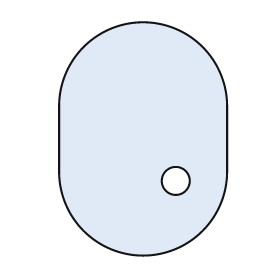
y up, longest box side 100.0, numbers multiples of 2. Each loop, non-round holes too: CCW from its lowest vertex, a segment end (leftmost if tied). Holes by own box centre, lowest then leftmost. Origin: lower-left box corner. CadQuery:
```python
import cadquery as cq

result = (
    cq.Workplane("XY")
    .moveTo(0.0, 36.0)
    .threePointArc((36.0, 0.0), (72.0, 36.0))
    .lineTo(72.0, 64.0)
    .threePointArc((36.0, 100.0), (0.0, 64.0))
    .close()
    .moveTo(50.0, 32.0)
    .circle(6.0)
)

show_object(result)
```